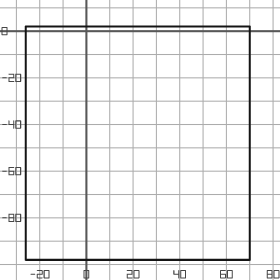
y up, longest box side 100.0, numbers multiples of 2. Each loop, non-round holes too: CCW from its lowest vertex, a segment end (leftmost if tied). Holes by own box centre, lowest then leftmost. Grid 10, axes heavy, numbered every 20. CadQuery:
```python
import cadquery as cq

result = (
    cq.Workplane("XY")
    .moveTo(-26.0, -98.0)
    .lineTo(70.0, -98.0)
    .lineTo(70.0, 2.0)
    .lineTo(-26.0, 2.0)
    .close()
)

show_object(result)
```